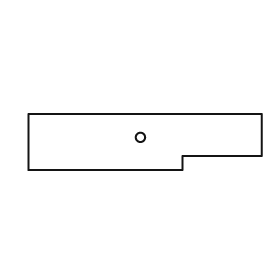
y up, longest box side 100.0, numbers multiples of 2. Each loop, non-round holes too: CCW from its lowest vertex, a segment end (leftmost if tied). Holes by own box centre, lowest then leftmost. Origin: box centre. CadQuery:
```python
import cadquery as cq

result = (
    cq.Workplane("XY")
    .moveTo(-50.0, -12.0)
    .lineTo(16.0, -12.0)
    .lineTo(16.0, -6.0)
    .lineTo(50.0, -6.0)
    .lineTo(50.0, 12.0)
    .lineTo(-50.0, 12.0)
    .close()
    .moveTo(-2.0, 2.0)
    .circle(2.0)
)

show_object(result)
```